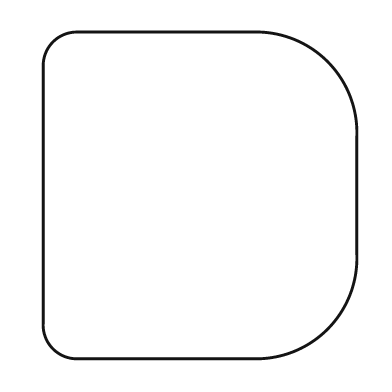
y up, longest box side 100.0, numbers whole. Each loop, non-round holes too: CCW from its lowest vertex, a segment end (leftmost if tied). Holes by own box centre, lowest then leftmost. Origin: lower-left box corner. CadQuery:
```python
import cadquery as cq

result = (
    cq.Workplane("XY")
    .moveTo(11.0, 0.0)
    .lineTo(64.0, 0.0)
    .threePointArc((87.0, 9.0), (96.0, 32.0))
    .lineTo(96.0, 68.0)
    .threePointArc((87.0, 91.0), (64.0, 100.0))
    .lineTo(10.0, 100.0)
    .threePointArc((3.0, 97.0), (0.0, 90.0))
    .lineTo(0.0, 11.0)
    .threePointArc((3.0, 3.0), (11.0, 0.0))
    .close()
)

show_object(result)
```